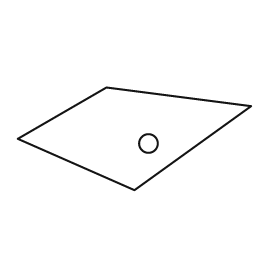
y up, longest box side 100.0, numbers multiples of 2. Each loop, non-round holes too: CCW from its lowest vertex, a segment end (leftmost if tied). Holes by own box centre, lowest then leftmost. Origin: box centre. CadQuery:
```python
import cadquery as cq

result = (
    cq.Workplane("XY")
    .moveTo(0.0, -22.0)
    .lineTo(50.0, 14.0)
    .lineTo(-12.0, 22.0)
    .lineTo(-50.0, 0.0)
    .close()
    .moveTo(6.0, -2.0)
    .circle(4.0)
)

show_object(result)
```